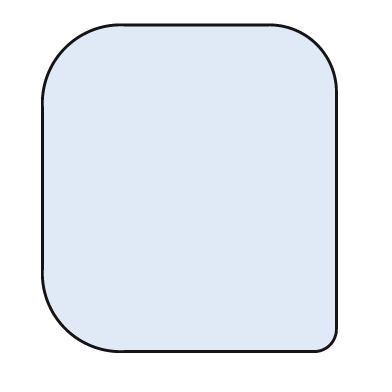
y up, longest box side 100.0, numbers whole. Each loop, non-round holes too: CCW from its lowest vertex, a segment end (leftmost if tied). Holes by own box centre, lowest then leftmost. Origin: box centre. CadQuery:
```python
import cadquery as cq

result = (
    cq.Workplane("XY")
    .moveTo(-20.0, -50.0)
    .lineTo(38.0, -50.0)
    .threePointArc((43.0, -48.0), (45.0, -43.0))
    .lineTo(45.0, 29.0)
    .threePointArc((39.0, 44.0), (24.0, 50.0))
    .lineTo(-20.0, 50.0)
    .threePointArc((-38.0, 43.0), (-45.0, 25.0))
    .lineTo(-45.0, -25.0)
    .threePointArc((-38.0, -43.0), (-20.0, -50.0))
    .close()
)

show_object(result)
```